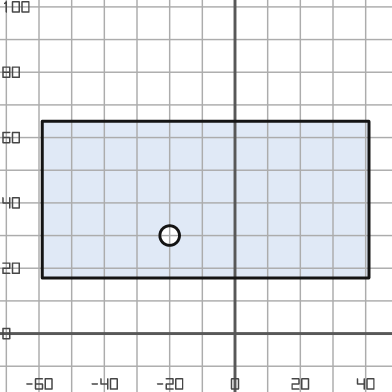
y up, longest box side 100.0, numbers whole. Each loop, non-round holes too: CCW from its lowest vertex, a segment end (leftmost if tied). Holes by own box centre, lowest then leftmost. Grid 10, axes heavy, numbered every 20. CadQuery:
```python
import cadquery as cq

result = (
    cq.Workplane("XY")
    .moveTo(-59.0, 17.0)
    .lineTo(41.0, 17.0)
    .lineTo(41.0, 65.0)
    .lineTo(-59.0, 65.0)
    .close()
    .moveTo(-20.0, 30.0)
    .circle(3.0)
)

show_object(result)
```